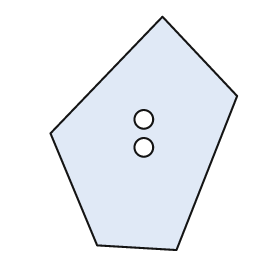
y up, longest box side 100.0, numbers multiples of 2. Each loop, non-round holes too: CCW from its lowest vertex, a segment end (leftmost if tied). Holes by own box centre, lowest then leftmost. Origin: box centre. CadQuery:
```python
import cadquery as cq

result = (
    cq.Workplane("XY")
    .moveTo(14.0, -50.0)
    .lineTo(40.0, 16.0)
    .lineTo(8.0, 50.0)
    .lineTo(-40.0, 0.0)
    .lineTo(-20.0, -48.0)
    .close()
    .moveTo(0.0, -6.0)
    .circle(4.0)
    .moveTo(0.0, 6.0)
    .circle(4.0)
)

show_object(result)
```